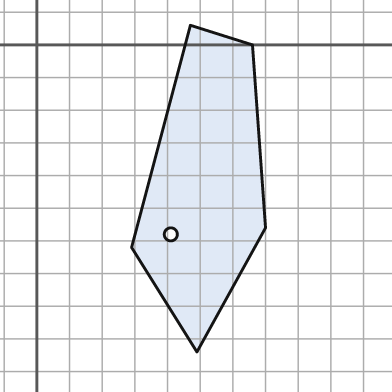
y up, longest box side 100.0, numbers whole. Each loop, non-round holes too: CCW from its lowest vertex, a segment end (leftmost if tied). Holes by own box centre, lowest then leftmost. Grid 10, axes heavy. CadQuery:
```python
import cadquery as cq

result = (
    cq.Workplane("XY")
    .moveTo(49.0, -94.0)
    .lineTo(70.0, -56.0)
    .lineTo(66.0, 0.0)
    .lineTo(47.0, 6.0)
    .lineTo(29.0, -62.0)
    .close()
    .moveTo(41.0, -58.0)
    .circle(2.0)
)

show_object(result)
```